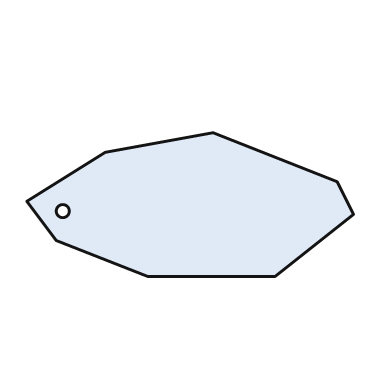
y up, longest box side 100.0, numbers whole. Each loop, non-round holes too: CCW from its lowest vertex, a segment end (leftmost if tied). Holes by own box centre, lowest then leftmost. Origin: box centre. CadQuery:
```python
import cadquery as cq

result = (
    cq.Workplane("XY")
    .moveTo(-13.0, -22.0)
    .lineTo(26.0, -22.0)
    .lineTo(50.0, -3.0)
    .lineTo(45.0, 7.0)
    .lineTo(7.0, 22.0)
    .lineTo(-26.0, 16.0)
    .lineTo(-50.0, 1.0)
    .lineTo(-41.0, -11.0)
    .close()
    .moveTo(-39.0, -2.0)
    .circle(2.0)
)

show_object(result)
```